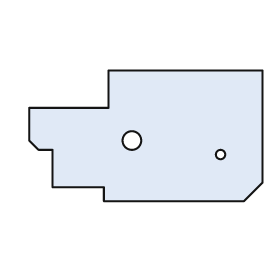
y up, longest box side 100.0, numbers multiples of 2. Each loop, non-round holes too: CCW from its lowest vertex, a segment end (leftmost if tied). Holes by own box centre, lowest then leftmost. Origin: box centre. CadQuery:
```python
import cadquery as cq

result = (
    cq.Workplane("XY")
    .moveTo(-18.0, -28.0)
    .lineTo(42.0, -28.0)
    .lineTo(50.0, -20.0)
    .lineTo(50.0, 28.0)
    .lineTo(-16.0, 28.0)
    .lineTo(-16.0, 12.0)
    .lineTo(-50.0, 12.0)
    .lineTo(-50.0, -2.0)
    .lineTo(-46.0, -6.0)
    .lineTo(-40.0, -6.0)
    .lineTo(-40.0, -22.0)
    .lineTo(-18.0, -22.0)
    .close()
    .moveTo(32.0, -8.0)
    .circle(2.0)
    .moveTo(-6.0, -2.0)
    .circle(4.0)
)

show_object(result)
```